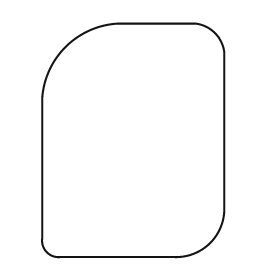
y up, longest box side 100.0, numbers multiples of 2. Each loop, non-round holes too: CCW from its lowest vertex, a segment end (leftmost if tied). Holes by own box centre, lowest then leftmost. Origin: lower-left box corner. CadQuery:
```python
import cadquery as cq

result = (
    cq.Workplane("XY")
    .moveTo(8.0, 0.0)
    .lineTo(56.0, 0.0)
    .threePointArc((72.0, 6.0), (78.0, 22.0))
    .lineTo(78.0, 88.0)
    .threePointArc((74.0, 96.0), (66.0, 100.0))
    .lineTo(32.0, 100.0)
    .threePointArc((10.0, 90.0), (0.0, 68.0))
    .lineTo(0.0, 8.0)
    .threePointArc((2.0, 2.0), (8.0, 0.0))
    .close()
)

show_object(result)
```